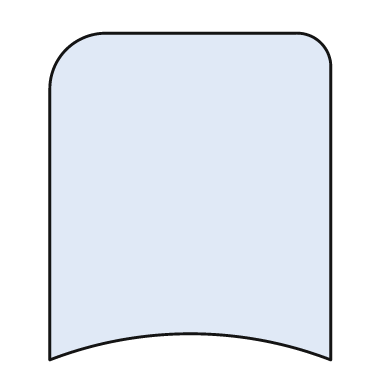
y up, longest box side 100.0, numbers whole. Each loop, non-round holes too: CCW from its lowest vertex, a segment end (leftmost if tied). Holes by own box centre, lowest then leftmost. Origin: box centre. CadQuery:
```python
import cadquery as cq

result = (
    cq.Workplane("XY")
    .moveTo(-43.0, -50.0)
    .threePointArc((0.0, -42.0), (43.0, -50.0))
    .lineTo(43.0, 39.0)
    .threePointArc((40.0, 47.0), (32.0, 50.0))
    .lineTo(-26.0, 50.0)
    .threePointArc((-38.0, 45.0), (-43.0, 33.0))
    .close()
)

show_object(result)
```